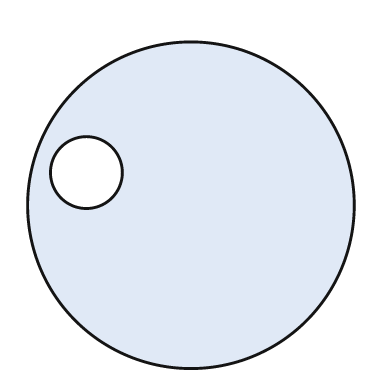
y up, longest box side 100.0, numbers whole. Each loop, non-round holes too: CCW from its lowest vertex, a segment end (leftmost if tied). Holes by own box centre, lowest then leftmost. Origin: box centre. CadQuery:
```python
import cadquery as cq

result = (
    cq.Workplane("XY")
    .moveTo(0.0, 0.0)
    .circle(50.0)
    .moveTo(-32.0, 10.0)
    .circle(11.0)
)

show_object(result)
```